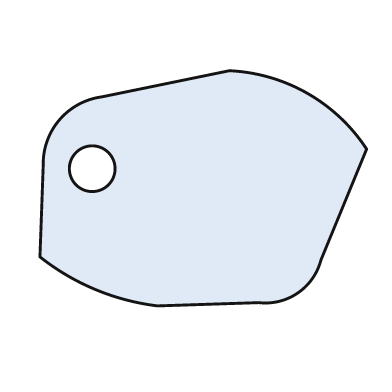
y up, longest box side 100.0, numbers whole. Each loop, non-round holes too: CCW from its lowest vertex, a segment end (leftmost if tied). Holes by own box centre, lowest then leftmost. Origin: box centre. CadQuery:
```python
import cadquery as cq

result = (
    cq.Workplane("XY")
    .moveTo(-14.0, -36.0)
    .lineTo(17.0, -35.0)
    .threePointArc((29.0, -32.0), (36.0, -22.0))
    .lineTo(50.0, 12.0)
    .threePointArc((32.0, 29.0), (8.0, 36.0))
    .lineTo(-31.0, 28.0)
    .threePointArc((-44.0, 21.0), (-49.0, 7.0))
    .lineTo(-50.0, -21.0)
    .threePointArc((-33.0, -31.0), (-14.0, -36.0))
    .close()
    .moveTo(-34.0, 6.0)
    .circle(7.0)
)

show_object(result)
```